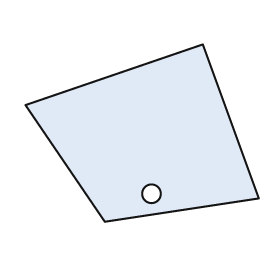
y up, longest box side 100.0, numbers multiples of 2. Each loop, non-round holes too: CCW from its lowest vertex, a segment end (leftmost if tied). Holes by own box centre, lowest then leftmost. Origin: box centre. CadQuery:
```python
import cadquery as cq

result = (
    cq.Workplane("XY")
    .moveTo(-16.0, -38.0)
    .lineTo(50.0, -28.0)
    .lineTo(26.0, 38.0)
    .lineTo(-50.0, 12.0)
    .close()
    .moveTo(4.0, -26.0)
    .circle(4.0)
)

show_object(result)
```